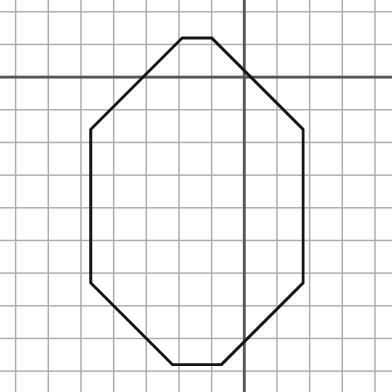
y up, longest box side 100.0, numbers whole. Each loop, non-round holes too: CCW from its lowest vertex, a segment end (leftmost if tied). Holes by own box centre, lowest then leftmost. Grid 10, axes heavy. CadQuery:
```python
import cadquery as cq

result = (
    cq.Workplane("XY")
    .moveTo(-22.0, -88.0)
    .lineTo(-7.0, -88.0)
    .lineTo(18.0, -63.0)
    .lineTo(18.0, -16.0)
    .lineTo(-10.0, 12.0)
    .lineTo(-19.0, 12.0)
    .lineTo(-47.0, -16.0)
    .lineTo(-47.0, -63.0)
    .close()
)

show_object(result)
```